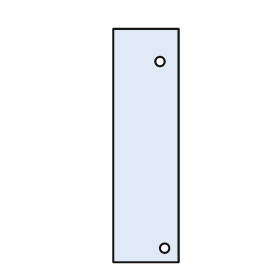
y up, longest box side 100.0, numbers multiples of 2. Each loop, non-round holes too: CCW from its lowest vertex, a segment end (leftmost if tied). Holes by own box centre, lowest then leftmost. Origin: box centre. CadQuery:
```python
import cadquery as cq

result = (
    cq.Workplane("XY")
    .moveTo(-14.0, -50.0)
    .lineTo(14.0, -50.0)
    .lineTo(14.0, 50.0)
    .lineTo(-14.0, 50.0)
    .close()
    .moveTo(8.0, -44.0)
    .circle(2.0)
    .moveTo(6.0, 36.0)
    .circle(2.0)
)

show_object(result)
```